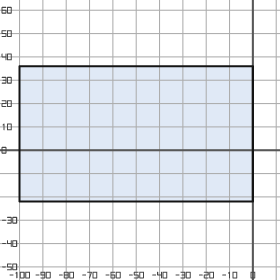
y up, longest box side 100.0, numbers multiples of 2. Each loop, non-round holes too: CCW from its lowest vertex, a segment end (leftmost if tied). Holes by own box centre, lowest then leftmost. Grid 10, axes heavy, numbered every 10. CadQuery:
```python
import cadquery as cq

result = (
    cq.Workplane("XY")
    .moveTo(-100.0, -22.0)
    .lineTo(0.0, -22.0)
    .lineTo(0.0, 36.0)
    .lineTo(-100.0, 36.0)
    .close()
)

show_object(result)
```